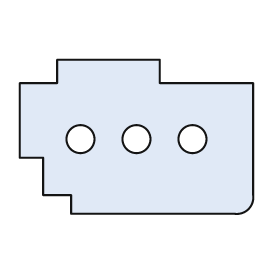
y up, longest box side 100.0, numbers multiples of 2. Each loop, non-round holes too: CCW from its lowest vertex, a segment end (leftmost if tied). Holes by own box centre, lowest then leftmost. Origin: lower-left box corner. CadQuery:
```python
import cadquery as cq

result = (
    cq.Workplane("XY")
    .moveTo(22.0, 0.0)
    .lineTo(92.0, 0.0)
    .threePointArc((98.0, 2.0), (100.0, 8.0))
    .lineTo(100.0, 56.0)
    .lineTo(60.0, 56.0)
    .lineTo(60.0, 66.0)
    .lineTo(16.0, 66.0)
    .lineTo(16.0, 56.0)
    .lineTo(0.0, 56.0)
    .lineTo(0.0, 24.0)
    .lineTo(10.0, 24.0)
    .lineTo(10.0, 8.0)
    .lineTo(22.0, 8.0)
    .close()
    .moveTo(26.0, 32.0)
    .circle(6.0)
    .moveTo(50.0, 32.0)
    .circle(6.0)
    .moveTo(74.0, 32.0)
    .circle(6.0)
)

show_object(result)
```